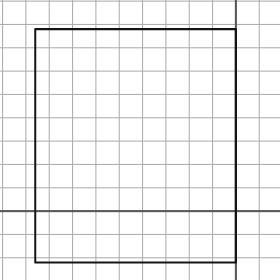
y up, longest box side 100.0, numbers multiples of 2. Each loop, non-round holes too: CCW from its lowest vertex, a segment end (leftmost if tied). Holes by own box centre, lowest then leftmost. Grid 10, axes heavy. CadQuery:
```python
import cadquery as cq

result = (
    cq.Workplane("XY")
    .moveTo(-86.0, -22.0)
    .lineTo(0.0, -22.0)
    .lineTo(0.0, 78.0)
    .lineTo(-86.0, 78.0)
    .close()
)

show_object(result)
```